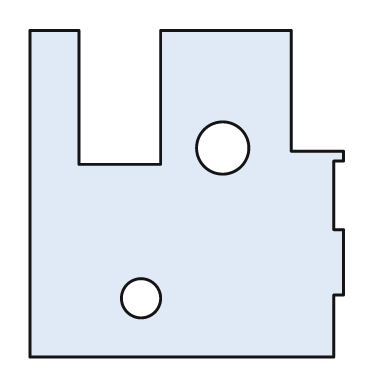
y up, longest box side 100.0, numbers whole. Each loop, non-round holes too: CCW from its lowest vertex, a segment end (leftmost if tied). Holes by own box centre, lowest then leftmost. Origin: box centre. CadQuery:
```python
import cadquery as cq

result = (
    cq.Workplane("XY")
    .moveTo(-48.0, -50.0)
    .lineTo(45.0, -50.0)
    .lineTo(45.0, -31.0)
    .lineTo(48.0, -31.0)
    .lineTo(48.0, -11.0)
    .lineTo(45.0, -11.0)
    .lineTo(45.0, 10.0)
    .lineTo(48.0, 10.0)
    .lineTo(48.0, 13.0)
    .lineTo(32.0, 13.0)
    .lineTo(32.0, 50.0)
    .lineTo(-8.0, 50.0)
    .lineTo(-8.0, 9.0)
    .lineTo(-33.0, 9.0)
    .lineTo(-33.0, 50.0)
    .lineTo(-48.0, 50.0)
    .close()
    .moveTo(-14.0, -32.0)
    .circle(6.0)
    .moveTo(11.0, 14.0)
    .circle(8.0)
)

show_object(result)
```